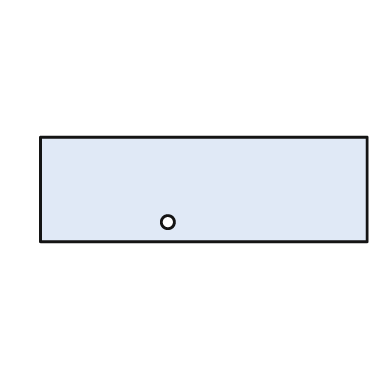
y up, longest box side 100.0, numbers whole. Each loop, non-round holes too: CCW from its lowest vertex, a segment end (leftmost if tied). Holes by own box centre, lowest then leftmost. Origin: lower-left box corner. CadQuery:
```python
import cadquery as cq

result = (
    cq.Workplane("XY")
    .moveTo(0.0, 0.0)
    .lineTo(100.0, 0.0)
    .lineTo(100.0, 32.0)
    .lineTo(0.0, 32.0)
    .close()
    .moveTo(39.0, 6.0)
    .circle(2.0)
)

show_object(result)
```